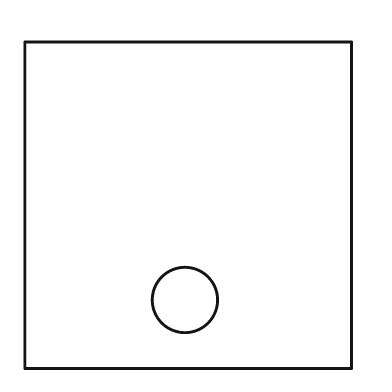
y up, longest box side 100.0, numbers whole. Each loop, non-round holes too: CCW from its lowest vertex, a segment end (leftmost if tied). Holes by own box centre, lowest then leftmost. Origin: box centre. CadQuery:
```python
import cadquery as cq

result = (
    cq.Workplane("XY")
    .moveTo(-50.0, -50.0)
    .lineTo(50.0, -50.0)
    .lineTo(50.0, 50.0)
    .lineTo(-50.0, 50.0)
    .close()
    .moveTo(-1.0, -29.0)
    .circle(10.0)
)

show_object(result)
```